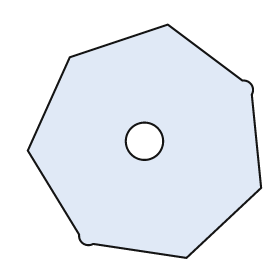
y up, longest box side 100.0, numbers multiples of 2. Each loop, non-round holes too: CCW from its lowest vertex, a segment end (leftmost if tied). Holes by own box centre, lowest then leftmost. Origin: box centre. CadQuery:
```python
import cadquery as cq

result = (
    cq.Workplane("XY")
    .moveTo(18.0, -50.0)
    .lineTo(50.0, -20.0)
    .lineTo(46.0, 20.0)
    .threePointArc((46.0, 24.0), (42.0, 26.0))
    .lineTo(10.0, 50.0)
    .lineTo(-32.0, 36.0)
    .lineTo(-50.0, -4.0)
    .lineTo(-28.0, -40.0)
    .threePointArc((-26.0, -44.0), (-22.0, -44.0))
    .close()
    .moveTo(0.0, 0.0)
    .circle(8.0)
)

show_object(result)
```